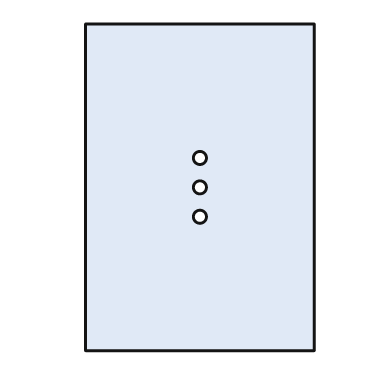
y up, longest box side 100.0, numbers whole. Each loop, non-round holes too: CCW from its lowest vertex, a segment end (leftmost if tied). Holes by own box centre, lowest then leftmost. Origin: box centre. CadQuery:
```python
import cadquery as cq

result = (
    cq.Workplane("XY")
    .moveTo(-35.0, -50.0)
    .lineTo(35.0, -50.0)
    .lineTo(35.0, 50.0)
    .lineTo(-35.0, 50.0)
    .close()
    .moveTo(0.0, -9.0)
    .circle(2.0)
    .moveTo(0.0, 0.0)
    .circle(2.0)
    .moveTo(0.0, 9.0)
    .circle(2.0)
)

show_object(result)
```